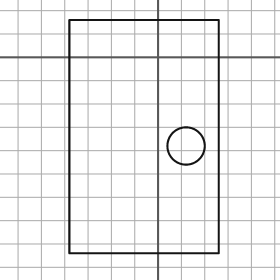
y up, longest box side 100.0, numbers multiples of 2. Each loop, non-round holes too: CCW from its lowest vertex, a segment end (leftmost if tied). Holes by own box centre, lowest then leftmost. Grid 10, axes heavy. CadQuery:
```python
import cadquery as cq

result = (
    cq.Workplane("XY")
    .moveTo(-38.0, -84.0)
    .lineTo(26.0, -84.0)
    .lineTo(26.0, 16.0)
    .lineTo(-38.0, 16.0)
    .close()
    .moveTo(12.0, -38.0)
    .circle(8.0)
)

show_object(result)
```